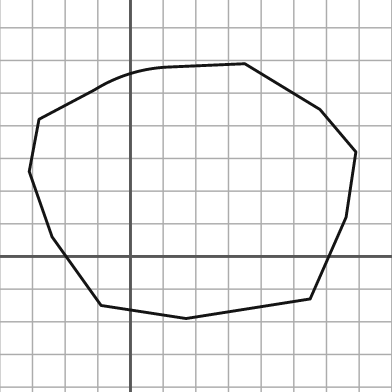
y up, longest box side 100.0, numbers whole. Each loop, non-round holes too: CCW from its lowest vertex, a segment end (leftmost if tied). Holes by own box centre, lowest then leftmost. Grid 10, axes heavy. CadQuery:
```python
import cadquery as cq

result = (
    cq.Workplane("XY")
    .moveTo(17.0, -19.0)
    .lineTo(55.0, -13.0)
    .lineTo(66.0, 12.0)
    .lineTo(69.0, 32.0)
    .lineTo(58.0, 45.0)
    .lineTo(35.0, 59.0)
    .lineTo(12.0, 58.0)
    .threePointArc((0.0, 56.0), (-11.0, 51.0))
    .lineTo(-28.0, 42.0)
    .lineTo(-31.0, 26.0)
    .lineTo(-24.0, 6.0)
    .lineTo(-9.0, -15.0)
    .close()
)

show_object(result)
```